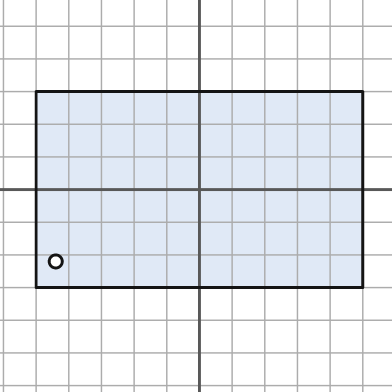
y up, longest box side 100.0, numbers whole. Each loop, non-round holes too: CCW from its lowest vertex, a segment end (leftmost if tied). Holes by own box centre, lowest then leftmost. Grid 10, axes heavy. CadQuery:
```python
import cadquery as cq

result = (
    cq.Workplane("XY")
    .moveTo(-50.0, -30.0)
    .lineTo(50.0, -30.0)
    .lineTo(50.0, 30.0)
    .lineTo(-50.0, 30.0)
    .close()
    .moveTo(-44.0, -22.0)
    .circle(2.0)
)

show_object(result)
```